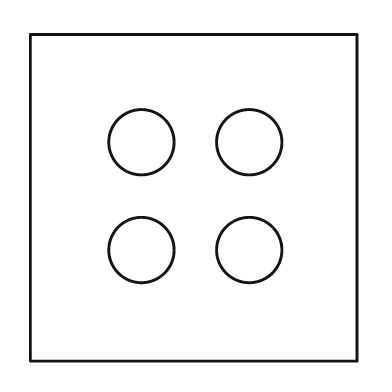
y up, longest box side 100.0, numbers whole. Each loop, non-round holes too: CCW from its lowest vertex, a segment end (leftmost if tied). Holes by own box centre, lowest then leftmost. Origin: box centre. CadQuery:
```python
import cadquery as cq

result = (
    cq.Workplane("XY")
    .moveTo(-50.0, -50.0)
    .lineTo(50.0, -50.0)
    .lineTo(50.0, 50.0)
    .lineTo(-50.0, 50.0)
    .close()
    .moveTo(-16.0, -16.0)
    .circle(10.0)
    .moveTo(17.0, -16.0)
    .circle(10.0)
    .moveTo(-16.0, 17.0)
    .circle(10.0)
    .moveTo(17.0, 17.0)
    .circle(10.0)
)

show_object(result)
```